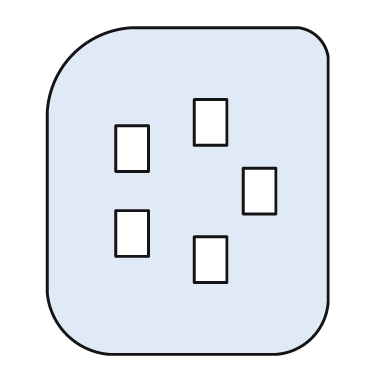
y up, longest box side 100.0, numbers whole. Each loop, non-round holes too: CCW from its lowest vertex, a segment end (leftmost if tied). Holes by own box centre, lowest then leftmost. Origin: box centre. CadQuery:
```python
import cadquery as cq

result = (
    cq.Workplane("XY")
    .moveTo(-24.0, -50.0)
    .lineTo(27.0, -50.0)
    .threePointArc((38.0, -45.0), (43.0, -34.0))
    .lineTo(43.0, 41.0)
    .threePointArc((40.0, 47.0), (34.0, 50.0))
    .lineTo(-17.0, 50.0)
    .threePointArc((-35.0, 42.0), (-43.0, 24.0))
    .lineTo(-43.0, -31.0)
    .threePointArc((-37.0, -44.0), (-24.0, -50.0))
    .close()
    .moveTo(2.0, -28.0)
    .lineTo(12.0, -28.0)
    .lineTo(12.0, -14.0)
    .lineTo(2.0, -14.0)
    .close()
    .moveTo(-22.0, -20.0)
    .lineTo(-12.0, -20.0)
    .lineTo(-12.0, -6.0)
    .lineTo(-22.0, -6.0)
    .close()
    .moveTo(17.0, -7.0)
    .lineTo(27.0, -7.0)
    .lineTo(27.0, 7.0)
    .lineTo(17.0, 7.0)
    .close()
    .moveTo(-22.0, 6.0)
    .lineTo(-12.0, 6.0)
    .lineTo(-12.0, 20.0)
    .lineTo(-22.0, 20.0)
    .close()
    .moveTo(2.0, 14.0)
    .lineTo(12.0, 14.0)
    .lineTo(12.0, 28.0)
    .lineTo(2.0, 28.0)
    .close()
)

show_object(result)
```